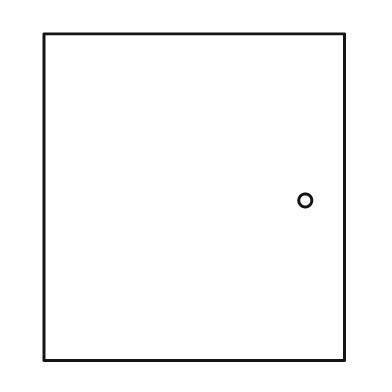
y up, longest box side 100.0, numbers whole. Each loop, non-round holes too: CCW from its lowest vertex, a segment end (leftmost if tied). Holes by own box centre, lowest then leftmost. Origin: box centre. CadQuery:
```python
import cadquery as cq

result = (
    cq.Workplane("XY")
    .moveTo(-46.0, -50.0)
    .lineTo(46.0, -50.0)
    .lineTo(46.0, 50.0)
    .lineTo(-46.0, 50.0)
    .close()
    .moveTo(34.0, -1.0)
    .circle(2.0)
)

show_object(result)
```